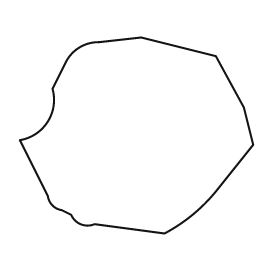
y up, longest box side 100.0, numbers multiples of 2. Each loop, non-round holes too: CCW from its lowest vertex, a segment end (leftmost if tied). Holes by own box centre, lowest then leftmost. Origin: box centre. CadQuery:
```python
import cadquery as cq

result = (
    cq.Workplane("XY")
    .moveTo(12.0, -42.0)
    .threePointArc((24.0, -34.0), (34.0, -24.0))
    .lineTo(50.0, -4.0)
    .lineTo(46.0, 12.0)
    .lineTo(34.0, 34.0)
    .lineTo(2.0, 42.0)
    .lineTo(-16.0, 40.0)
    .threePointArc((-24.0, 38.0), (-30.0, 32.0))
    .lineTo(-36.0, 20.0)
    .threePointArc((-38.0, 6.0), (-50.0, -2.0))
    .lineTo(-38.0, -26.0)
    .threePointArc((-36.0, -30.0), (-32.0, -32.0))
    .lineTo(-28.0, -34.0)
    .threePointArc((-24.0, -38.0), (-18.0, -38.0))
    .close()
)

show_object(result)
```